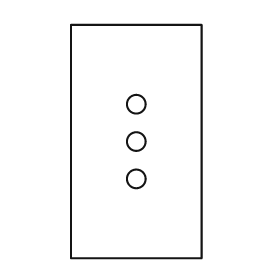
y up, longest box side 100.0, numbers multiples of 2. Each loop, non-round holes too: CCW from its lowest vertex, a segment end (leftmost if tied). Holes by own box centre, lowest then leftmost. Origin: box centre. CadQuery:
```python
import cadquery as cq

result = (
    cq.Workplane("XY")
    .moveTo(-28.0, -50.0)
    .lineTo(28.0, -50.0)
    .lineTo(28.0, 50.0)
    .lineTo(-28.0, 50.0)
    .close()
    .moveTo(0.0, -16.0)
    .circle(4.0)
    .moveTo(0.0, 0.0)
    .circle(4.0)
    .moveTo(0.0, 16.0)
    .circle(4.0)
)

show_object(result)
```